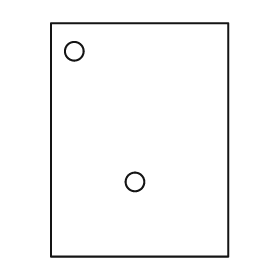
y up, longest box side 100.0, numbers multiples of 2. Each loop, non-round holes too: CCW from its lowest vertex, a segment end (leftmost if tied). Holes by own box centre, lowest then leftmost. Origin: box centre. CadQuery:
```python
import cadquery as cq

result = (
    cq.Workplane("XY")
    .moveTo(-38.0, -50.0)
    .lineTo(38.0, -50.0)
    .lineTo(38.0, 50.0)
    .lineTo(-38.0, 50.0)
    .close()
    .moveTo(-2.0, -18.0)
    .circle(4.0)
    .moveTo(-28.0, 38.0)
    .circle(4.0)
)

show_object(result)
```